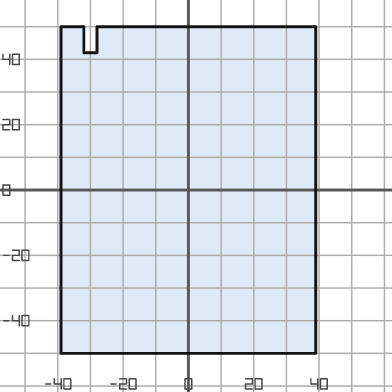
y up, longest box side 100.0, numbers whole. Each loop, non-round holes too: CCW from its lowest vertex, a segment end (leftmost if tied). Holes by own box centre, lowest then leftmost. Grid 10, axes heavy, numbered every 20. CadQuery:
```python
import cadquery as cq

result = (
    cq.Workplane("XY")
    .moveTo(-39.0, -50.0)
    .lineTo(39.0, -50.0)
    .lineTo(39.0, 50.0)
    .lineTo(-28.0, 50.0)
    .lineTo(-28.0, 42.0)
    .lineTo(-32.0, 42.0)
    .lineTo(-32.0, 50.0)
    .lineTo(-39.0, 50.0)
    .close()
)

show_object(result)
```